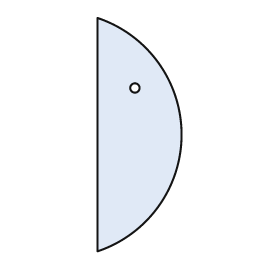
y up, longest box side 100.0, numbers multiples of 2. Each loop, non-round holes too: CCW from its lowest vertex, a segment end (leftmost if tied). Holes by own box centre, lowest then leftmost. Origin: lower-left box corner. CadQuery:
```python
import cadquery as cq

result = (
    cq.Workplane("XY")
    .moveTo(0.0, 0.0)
    .threePointArc((36.0, 50.0), (0.0, 100.0))
    .close()
    .moveTo(16.0, 70.0)
    .circle(2.0)
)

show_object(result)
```